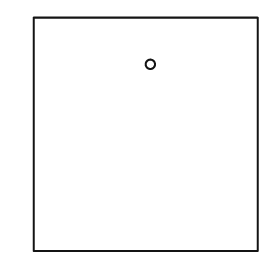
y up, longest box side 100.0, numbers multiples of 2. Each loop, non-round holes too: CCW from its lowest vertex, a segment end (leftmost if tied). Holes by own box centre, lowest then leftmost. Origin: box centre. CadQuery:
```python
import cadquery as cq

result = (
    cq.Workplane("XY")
    .moveTo(-48.0, -50.0)
    .lineTo(48.0, -50.0)
    .lineTo(48.0, 50.0)
    .lineTo(-48.0, 50.0)
    .close()
    .moveTo(2.0, 30.0)
    .circle(2.0)
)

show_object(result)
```